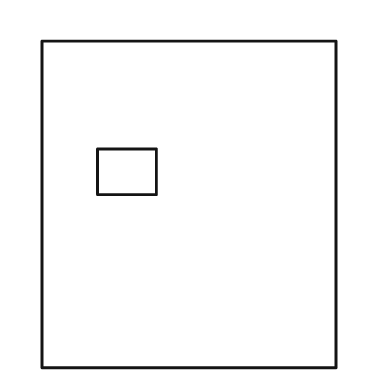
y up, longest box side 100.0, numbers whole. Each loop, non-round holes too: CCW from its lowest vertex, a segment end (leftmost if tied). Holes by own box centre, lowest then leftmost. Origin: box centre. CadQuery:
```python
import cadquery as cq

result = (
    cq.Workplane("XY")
    .moveTo(-45.0, -50.0)
    .lineTo(45.0, -50.0)
    .lineTo(45.0, 50.0)
    .lineTo(-45.0, 50.0)
    .close()
    .moveTo(-28.0, 3.0)
    .lineTo(-10.0, 3.0)
    .lineTo(-10.0, 17.0)
    .lineTo(-28.0, 17.0)
    .close()
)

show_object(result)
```